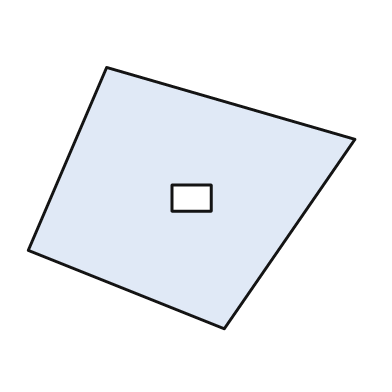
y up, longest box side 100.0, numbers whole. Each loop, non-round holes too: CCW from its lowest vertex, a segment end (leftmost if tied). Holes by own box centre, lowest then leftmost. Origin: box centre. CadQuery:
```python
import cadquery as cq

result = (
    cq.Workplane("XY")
    .moveTo(10.0, -40.0)
    .lineTo(50.0, 18.0)
    .lineTo(-26.0, 40.0)
    .lineTo(-50.0, -16.0)
    .close()
    .moveTo(-6.0, -4.0)
    .lineTo(6.0, -4.0)
    .lineTo(6.0, 4.0)
    .lineTo(-6.0, 4.0)
    .close()
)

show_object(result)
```